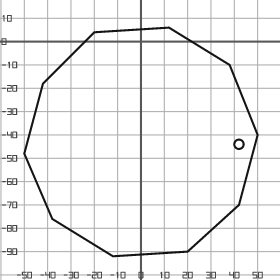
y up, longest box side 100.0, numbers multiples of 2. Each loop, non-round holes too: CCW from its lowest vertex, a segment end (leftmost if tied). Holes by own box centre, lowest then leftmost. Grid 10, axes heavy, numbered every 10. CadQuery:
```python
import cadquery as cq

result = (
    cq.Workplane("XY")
    .moveTo(-12.0, -92.0)
    .lineTo(20.0, -90.0)
    .lineTo(42.0, -70.0)
    .lineTo(50.0, -40.0)
    .lineTo(38.0, -10.0)
    .lineTo(12.0, 6.0)
    .lineTo(-20.0, 4.0)
    .lineTo(-42.0, -18.0)
    .lineTo(-50.0, -48.0)
    .lineTo(-38.0, -76.0)
    .close()
    .moveTo(42.0, -44.0)
    .circle(2.0)
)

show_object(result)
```